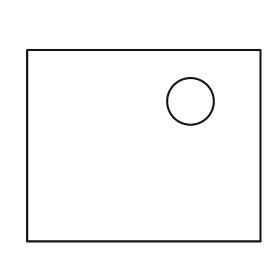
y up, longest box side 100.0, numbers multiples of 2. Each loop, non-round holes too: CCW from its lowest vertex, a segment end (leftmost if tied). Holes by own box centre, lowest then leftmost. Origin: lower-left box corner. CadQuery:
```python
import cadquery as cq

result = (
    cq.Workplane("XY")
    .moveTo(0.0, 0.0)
    .lineTo(100.0, 0.0)
    .lineTo(100.0, 82.0)
    .lineTo(0.0, 82.0)
    .close()
    .moveTo(70.0, 60.0)
    .circle(10.0)
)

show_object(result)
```